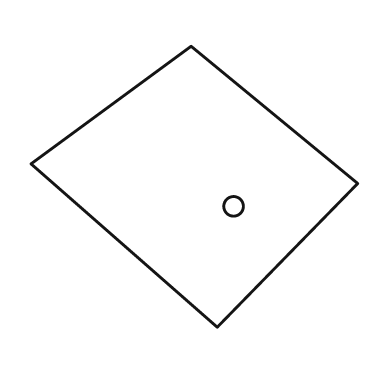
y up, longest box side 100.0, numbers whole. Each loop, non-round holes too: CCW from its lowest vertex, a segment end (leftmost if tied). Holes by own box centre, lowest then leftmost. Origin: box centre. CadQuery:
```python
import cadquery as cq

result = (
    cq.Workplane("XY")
    .moveTo(7.0, -43.0)
    .lineTo(50.0, 1.0)
    .lineTo(-1.0, 43.0)
    .lineTo(-50.0, 7.0)
    .close()
    .moveTo(12.0, -6.0)
    .circle(3.0)
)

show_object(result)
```